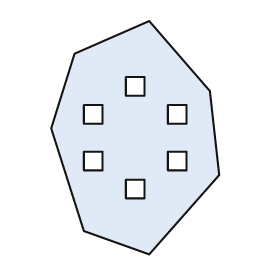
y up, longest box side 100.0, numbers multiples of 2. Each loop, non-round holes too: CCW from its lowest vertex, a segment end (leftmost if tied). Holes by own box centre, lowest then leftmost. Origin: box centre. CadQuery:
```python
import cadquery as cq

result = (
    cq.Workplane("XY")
    .moveTo(6.0, -50.0)
    .lineTo(36.0, -16.0)
    .lineTo(32.0, 20.0)
    .lineTo(6.0, 50.0)
    .lineTo(-26.0, 36.0)
    .lineTo(-36.0, 4.0)
    .lineTo(-22.0, -40.0)
    .close()
    .moveTo(-4.0, -26.0)
    .lineTo(4.0, -26.0)
    .lineTo(4.0, -18.0)
    .lineTo(-4.0, -18.0)
    .close()
    .moveTo(-22.0, -14.0)
    .lineTo(-14.0, -14.0)
    .lineTo(-14.0, -6.0)
    .lineTo(-22.0, -6.0)
    .close()
    .moveTo(14.0, -14.0)
    .lineTo(22.0, -14.0)
    .lineTo(22.0, -6.0)
    .lineTo(14.0, -6.0)
    .close()
    .moveTo(-22.0, 6.0)
    .lineTo(-14.0, 6.0)
    .lineTo(-14.0, 14.0)
    .lineTo(-22.0, 14.0)
    .close()
    .moveTo(14.0, 6.0)
    .lineTo(22.0, 6.0)
    .lineTo(22.0, 14.0)
    .lineTo(14.0, 14.0)
    .close()
    .moveTo(-4.0, 18.0)
    .lineTo(4.0, 18.0)
    .lineTo(4.0, 26.0)
    .lineTo(-4.0, 26.0)
    .close()
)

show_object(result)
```